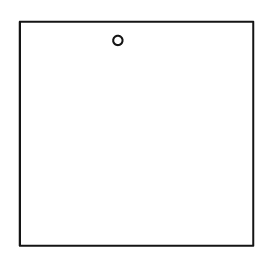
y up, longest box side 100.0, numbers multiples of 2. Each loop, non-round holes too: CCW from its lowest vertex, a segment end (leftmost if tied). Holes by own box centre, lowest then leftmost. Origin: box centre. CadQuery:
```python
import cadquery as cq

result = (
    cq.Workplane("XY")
    .moveTo(-50.0, -48.0)
    .lineTo(50.0, -48.0)
    .lineTo(50.0, 48.0)
    .lineTo(-50.0, 48.0)
    .close()
    .moveTo(-8.0, 40.0)
    .circle(2.0)
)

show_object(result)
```